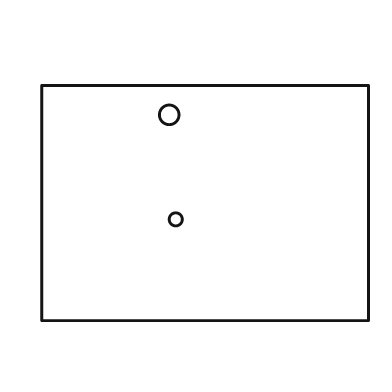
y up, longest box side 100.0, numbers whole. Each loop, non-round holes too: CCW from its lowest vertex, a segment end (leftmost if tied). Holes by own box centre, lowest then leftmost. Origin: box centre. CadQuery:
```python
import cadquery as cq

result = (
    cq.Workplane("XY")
    .moveTo(-50.0, -36.0)
    .lineTo(50.0, -36.0)
    .lineTo(50.0, 36.0)
    .lineTo(-50.0, 36.0)
    .close()
    .moveTo(-9.0, -5.0)
    .circle(2.0)
    .moveTo(-11.0, 27.0)
    .circle(3.0)
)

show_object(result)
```